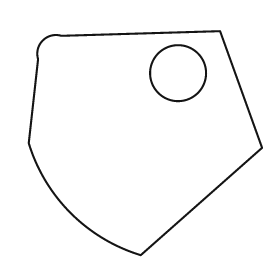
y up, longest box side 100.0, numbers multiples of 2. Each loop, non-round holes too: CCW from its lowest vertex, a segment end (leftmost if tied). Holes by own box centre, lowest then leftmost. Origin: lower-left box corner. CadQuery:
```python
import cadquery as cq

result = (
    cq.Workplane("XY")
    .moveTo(48.0, 0.0)
    .lineTo(100.0, 46.0)
    .lineTo(82.0, 96.0)
    .lineTo(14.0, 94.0)
    .threePointArc((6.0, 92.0), (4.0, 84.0))
    .lineTo(0.0, 48.0)
    .threePointArc((18.0, 18.0), (48.0, 0.0))
    .close()
    .moveTo(64.0, 78.0)
    .circle(12.0)
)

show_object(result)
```